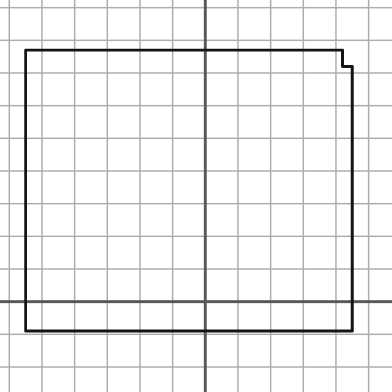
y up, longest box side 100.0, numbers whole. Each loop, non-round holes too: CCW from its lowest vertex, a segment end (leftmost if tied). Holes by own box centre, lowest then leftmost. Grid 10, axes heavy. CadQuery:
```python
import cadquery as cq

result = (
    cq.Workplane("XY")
    .moveTo(-55.0, -9.0)
    .lineTo(45.0, -9.0)
    .lineTo(45.0, 72.0)
    .lineTo(42.0, 72.0)
    .lineTo(42.0, 77.0)
    .lineTo(-55.0, 77.0)
    .close()
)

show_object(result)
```